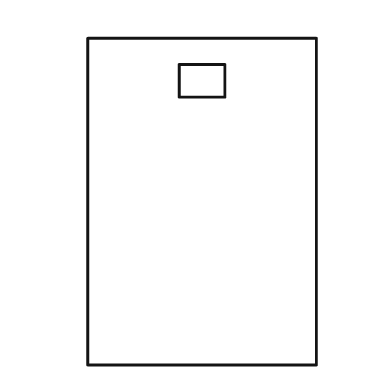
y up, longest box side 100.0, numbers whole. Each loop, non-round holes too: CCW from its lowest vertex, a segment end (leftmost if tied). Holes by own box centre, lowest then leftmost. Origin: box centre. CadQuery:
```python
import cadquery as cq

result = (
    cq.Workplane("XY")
    .moveTo(-35.0, -50.0)
    .lineTo(35.0, -50.0)
    .lineTo(35.0, 50.0)
    .lineTo(-35.0, 50.0)
    .close()
    .moveTo(-7.0, 32.0)
    .lineTo(7.0, 32.0)
    .lineTo(7.0, 42.0)
    .lineTo(-7.0, 42.0)
    .close()
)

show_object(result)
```